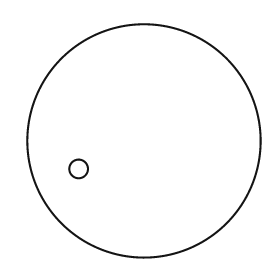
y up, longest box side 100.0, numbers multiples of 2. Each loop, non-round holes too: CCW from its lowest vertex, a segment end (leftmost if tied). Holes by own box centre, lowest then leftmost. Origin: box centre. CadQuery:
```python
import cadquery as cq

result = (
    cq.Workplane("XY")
    .moveTo(0.0, 0.0)
    .circle(50.0)
    .moveTo(-28.0, -12.0)
    .circle(4.0)
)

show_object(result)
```